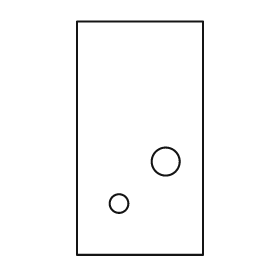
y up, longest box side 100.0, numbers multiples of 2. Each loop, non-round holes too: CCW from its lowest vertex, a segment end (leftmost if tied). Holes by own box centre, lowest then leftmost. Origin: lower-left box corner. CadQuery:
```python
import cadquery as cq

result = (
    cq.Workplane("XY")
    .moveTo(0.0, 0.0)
    .lineTo(54.0, 0.0)
    .lineTo(54.0, 100.0)
    .lineTo(0.0, 100.0)
    .close()
    .moveTo(18.0, 22.0)
    .circle(4.0)
    .moveTo(38.0, 40.0)
    .circle(6.0)
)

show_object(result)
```